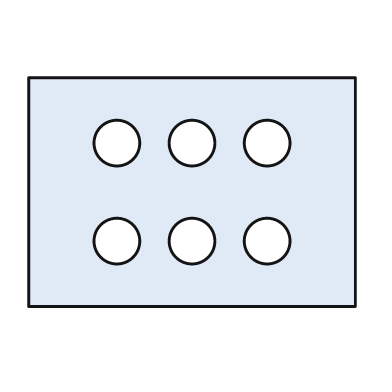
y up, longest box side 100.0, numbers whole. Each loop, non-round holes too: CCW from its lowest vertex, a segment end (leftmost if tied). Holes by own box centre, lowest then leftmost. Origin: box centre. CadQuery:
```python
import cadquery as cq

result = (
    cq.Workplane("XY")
    .moveTo(-50.0, -35.0)
    .lineTo(50.0, -35.0)
    .lineTo(50.0, 35.0)
    .lineTo(-50.0, 35.0)
    .close()
    .moveTo(-23.0, -15.0)
    .circle(7.0)
    .moveTo(0.0, -15.0)
    .circle(7.0)
    .moveTo(23.0, -15.0)
    .circle(7.0)
    .moveTo(-23.0, 15.0)
    .circle(7.0)
    .moveTo(0.0, 15.0)
    .circle(7.0)
    .moveTo(23.0, 15.0)
    .circle(7.0)
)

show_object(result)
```